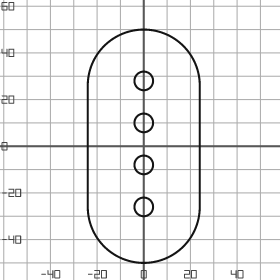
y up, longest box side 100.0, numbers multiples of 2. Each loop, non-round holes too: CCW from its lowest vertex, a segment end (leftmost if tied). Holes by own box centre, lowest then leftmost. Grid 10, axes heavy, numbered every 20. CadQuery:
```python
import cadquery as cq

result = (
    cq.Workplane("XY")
    .moveTo(-24.0, -26.0)
    .threePointArc((0.0, -50.0), (24.0, -26.0))
    .lineTo(24.0, 26.0)
    .threePointArc((0.0, 50.0), (-24.0, 26.0))
    .close()
    .moveTo(0.0, -26.0)
    .circle(4.0)
    .moveTo(0.0, -8.0)
    .circle(4.0)
    .moveTo(0.0, 10.0)
    .circle(4.0)
    .moveTo(0.0, 28.0)
    .circle(4.0)
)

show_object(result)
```